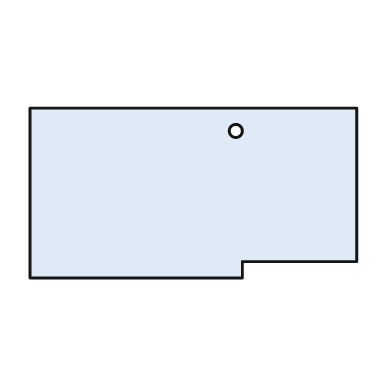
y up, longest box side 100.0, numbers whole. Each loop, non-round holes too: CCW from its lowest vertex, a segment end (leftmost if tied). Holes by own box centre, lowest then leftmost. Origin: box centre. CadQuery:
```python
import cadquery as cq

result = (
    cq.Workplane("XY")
    .moveTo(-50.0, -26.0)
    .lineTo(15.0, -26.0)
    .lineTo(15.0, -21.0)
    .lineTo(50.0, -21.0)
    .lineTo(50.0, 26.0)
    .lineTo(-50.0, 26.0)
    .close()
    .moveTo(13.0, 19.0)
    .circle(2.0)
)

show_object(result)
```